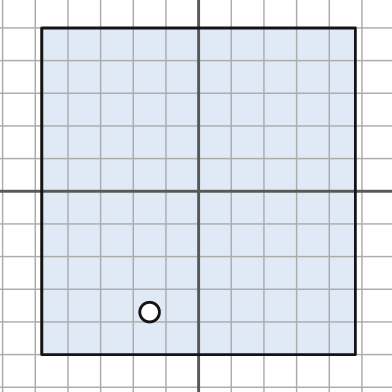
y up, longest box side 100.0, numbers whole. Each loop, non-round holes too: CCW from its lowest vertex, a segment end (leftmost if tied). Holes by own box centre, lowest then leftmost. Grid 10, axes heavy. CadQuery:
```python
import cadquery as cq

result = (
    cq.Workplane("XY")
    .moveTo(-48.0, -50.0)
    .lineTo(48.0, -50.0)
    .lineTo(48.0, 50.0)
    .lineTo(-48.0, 50.0)
    .close()
    .moveTo(-15.0, -37.0)
    .circle(3.0)
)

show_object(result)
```